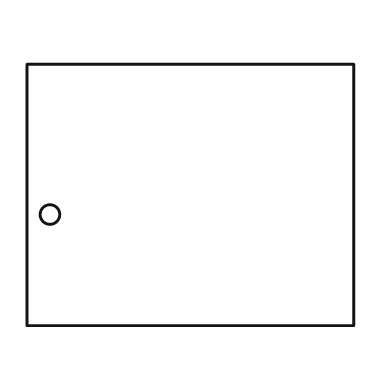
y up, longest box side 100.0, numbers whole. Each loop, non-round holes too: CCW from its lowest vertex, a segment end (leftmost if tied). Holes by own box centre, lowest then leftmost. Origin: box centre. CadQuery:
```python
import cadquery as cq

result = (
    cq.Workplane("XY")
    .moveTo(-50.0, -40.0)
    .lineTo(50.0, -40.0)
    .lineTo(50.0, 40.0)
    .lineTo(-50.0, 40.0)
    .close()
    .moveTo(-43.0, -6.0)
    .circle(3.0)
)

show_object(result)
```